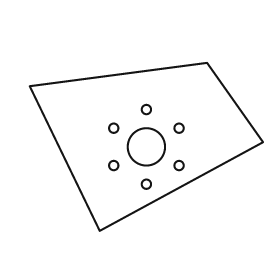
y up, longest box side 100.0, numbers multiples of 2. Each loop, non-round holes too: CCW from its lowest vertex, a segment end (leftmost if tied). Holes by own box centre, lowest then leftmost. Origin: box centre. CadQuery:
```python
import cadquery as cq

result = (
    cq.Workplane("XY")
    .moveTo(-20.0, -36.0)
    .lineTo(50.0, 2.0)
    .lineTo(26.0, 36.0)
    .lineTo(-50.0, 26.0)
    .close()
    .moveTo(0.0, -16.0)
    .circle(2.0)
    .moveTo(-14.0, -8.0)
    .circle(2.0)
    .moveTo(14.0, -8.0)
    .circle(2.0)
    .moveTo(0.0, 0.0)
    .circle(8.0)
    .moveTo(-14.0, 8.0)
    .circle(2.0)
    .moveTo(14.0, 8.0)
    .circle(2.0)
    .moveTo(0.0, 16.0)
    .circle(2.0)
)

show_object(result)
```